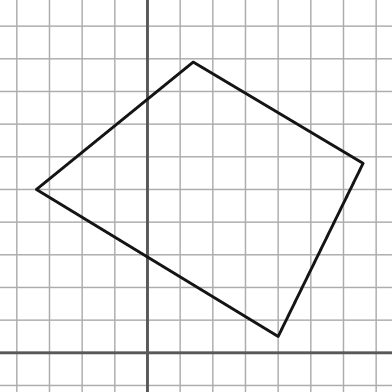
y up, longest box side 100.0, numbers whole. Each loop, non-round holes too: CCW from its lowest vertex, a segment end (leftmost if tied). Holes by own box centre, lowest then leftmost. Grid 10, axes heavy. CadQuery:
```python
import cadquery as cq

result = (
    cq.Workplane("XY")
    .moveTo(40.0, 5.0)
    .lineTo(66.0, 58.0)
    .lineTo(14.0, 89.0)
    .lineTo(-34.0, 50.0)
    .close()
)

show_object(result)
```